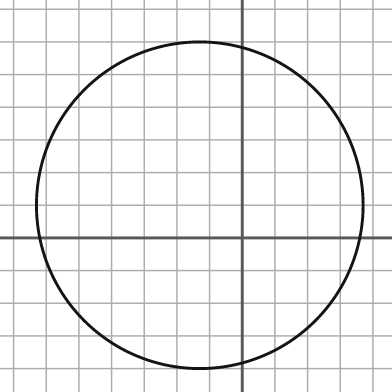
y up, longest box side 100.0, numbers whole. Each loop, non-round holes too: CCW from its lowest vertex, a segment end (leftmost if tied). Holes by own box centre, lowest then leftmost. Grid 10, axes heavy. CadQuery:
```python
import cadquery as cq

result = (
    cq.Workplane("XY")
    .moveTo(-13.0, 10.0)
    .circle(50.0)
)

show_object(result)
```